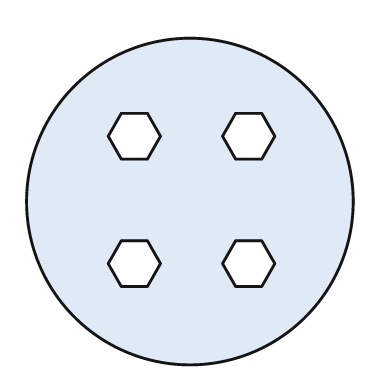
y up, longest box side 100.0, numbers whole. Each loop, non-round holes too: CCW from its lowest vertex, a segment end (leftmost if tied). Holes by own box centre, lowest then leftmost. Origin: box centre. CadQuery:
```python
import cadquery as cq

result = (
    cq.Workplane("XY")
    .moveTo(0.0, 0.0)
    .circle(50.0)
    .moveTo(-21.0, -26.0)
    .lineTo(-13.0, -26.0)
    .lineTo(-9.0, -19.0)
    .lineTo(-13.0, -12.0)
    .lineTo(-21.0, -12.0)
    .lineTo(-25.0, -19.0)
    .close()
    .moveTo(14.0, -26.0)
    .lineTo(22.0, -26.0)
    .lineTo(26.0, -19.0)
    .lineTo(22.0, -12.0)
    .lineTo(14.0, -12.0)
    .lineTo(10.0, -19.0)
    .close()
    .moveTo(-21.0, 13.0)
    .lineTo(-13.0, 13.0)
    .lineTo(-9.0, 20.0)
    .lineTo(-13.0, 27.0)
    .lineTo(-21.0, 27.0)
    .lineTo(-25.0, 20.0)
    .close()
    .moveTo(14.0, 13.0)
    .lineTo(22.0, 13.0)
    .lineTo(26.0, 20.0)
    .lineTo(22.0, 27.0)
    .lineTo(14.0, 27.0)
    .lineTo(10.0, 20.0)
    .close()
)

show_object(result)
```